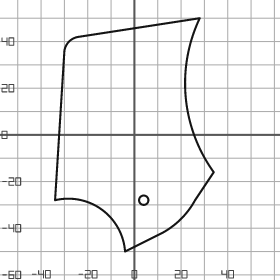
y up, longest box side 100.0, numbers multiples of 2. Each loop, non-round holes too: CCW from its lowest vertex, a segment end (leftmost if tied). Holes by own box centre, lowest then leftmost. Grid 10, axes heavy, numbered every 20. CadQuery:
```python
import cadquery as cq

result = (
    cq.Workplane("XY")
    .moveTo(-4.0, -50.0)
    .lineTo(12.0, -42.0)
    .threePointArc((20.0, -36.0), (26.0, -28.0))
    .lineTo(34.0, -16.0)
    .threePointArc((22.0, 16.0), (28.0, 50.0))
    .lineTo(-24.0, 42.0)
    .threePointArc((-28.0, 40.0), (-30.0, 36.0))
    .lineTo(-34.0, -28.0)
    .threePointArc((-14.0, -32.0), (-4.0, -50.0))
    .close()
    .moveTo(4.0, -28.0)
    .circle(2.0)
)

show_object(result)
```